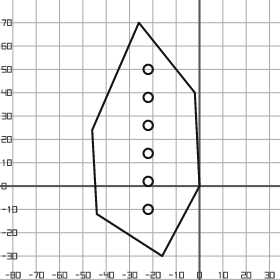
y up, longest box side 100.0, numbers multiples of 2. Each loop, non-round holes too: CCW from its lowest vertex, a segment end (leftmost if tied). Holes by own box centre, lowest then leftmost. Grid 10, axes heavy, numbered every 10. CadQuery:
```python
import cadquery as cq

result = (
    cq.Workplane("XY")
    .moveTo(-16.0, -30.0)
    .lineTo(0.0, 0.0)
    .lineTo(-2.0, 40.0)
    .lineTo(-26.0, 70.0)
    .lineTo(-46.0, 24.0)
    .lineTo(-44.0, -12.0)
    .close()
    .moveTo(-22.0, -10.0)
    .circle(2.0)
    .moveTo(-22.0, 2.0)
    .circle(2.0)
    .moveTo(-22.0, 14.0)
    .circle(2.0)
    .moveTo(-22.0, 26.0)
    .circle(2.0)
    .moveTo(-22.0, 38.0)
    .circle(2.0)
    .moveTo(-22.0, 50.0)
    .circle(2.0)
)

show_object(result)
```